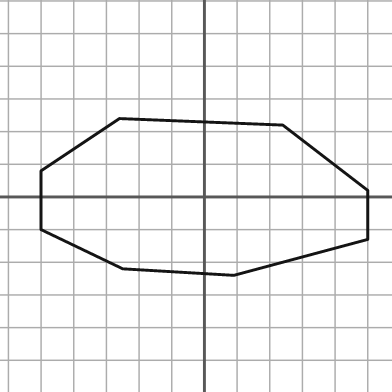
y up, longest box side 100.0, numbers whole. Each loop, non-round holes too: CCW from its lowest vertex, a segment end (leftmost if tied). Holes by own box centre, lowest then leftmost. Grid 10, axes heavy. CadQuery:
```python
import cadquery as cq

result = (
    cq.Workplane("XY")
    .moveTo(9.0, -24.0)
    .lineTo(50.0, -13.0)
    .lineTo(50.0, 2.0)
    .lineTo(24.0, 22.0)
    .lineTo(-26.0, 24.0)
    .lineTo(-50.0, 8.0)
    .lineTo(-50.0, -10.0)
    .lineTo(-25.0, -22.0)
    .close()
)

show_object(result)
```